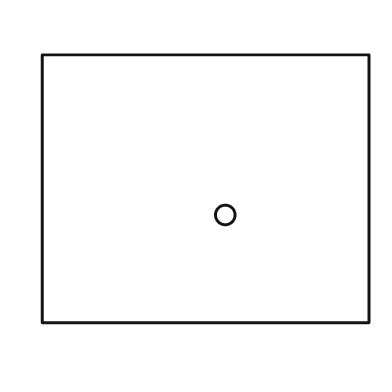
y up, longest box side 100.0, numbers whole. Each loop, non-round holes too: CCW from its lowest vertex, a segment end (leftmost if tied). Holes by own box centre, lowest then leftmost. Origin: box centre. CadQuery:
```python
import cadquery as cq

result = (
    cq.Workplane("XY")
    .moveTo(-50.0, -41.0)
    .lineTo(50.0, -41.0)
    .lineTo(50.0, 41.0)
    .lineTo(-50.0, 41.0)
    .close()
    .moveTo(6.0, -8.0)
    .circle(3.0)
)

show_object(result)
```